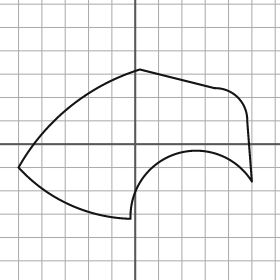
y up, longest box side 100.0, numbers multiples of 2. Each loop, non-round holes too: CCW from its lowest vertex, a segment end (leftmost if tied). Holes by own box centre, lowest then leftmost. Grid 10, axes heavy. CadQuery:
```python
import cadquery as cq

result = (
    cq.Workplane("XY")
    .moveTo(-2.0, -32.0)
    .threePointArc((18.0, -4.0), (50.0, -16.0))
    .lineTo(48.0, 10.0)
    .threePointArc((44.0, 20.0), (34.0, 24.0))
    .lineTo(2.0, 32.0)
    .threePointArc((-28.0, 16.0), (-50.0, -10.0))
    .threePointArc((-28.0, -26.0), (-2.0, -32.0))
    .close()
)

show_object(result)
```